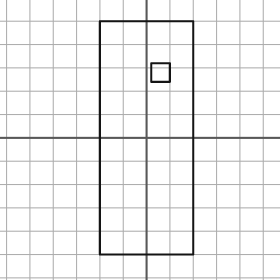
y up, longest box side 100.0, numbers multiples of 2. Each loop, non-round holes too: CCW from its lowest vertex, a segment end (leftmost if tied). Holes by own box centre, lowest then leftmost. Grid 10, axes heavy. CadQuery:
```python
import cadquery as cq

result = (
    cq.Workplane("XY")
    .moveTo(-20.0, -50.0)
    .lineTo(20.0, -50.0)
    .lineTo(20.0, 50.0)
    .lineTo(-20.0, 50.0)
    .close()
    .moveTo(2.0, 24.0)
    .lineTo(10.0, 24.0)
    .lineTo(10.0, 32.0)
    .lineTo(2.0, 32.0)
    .close()
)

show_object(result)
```